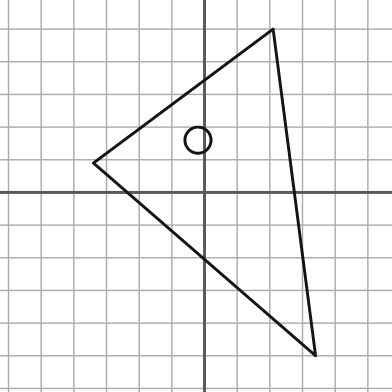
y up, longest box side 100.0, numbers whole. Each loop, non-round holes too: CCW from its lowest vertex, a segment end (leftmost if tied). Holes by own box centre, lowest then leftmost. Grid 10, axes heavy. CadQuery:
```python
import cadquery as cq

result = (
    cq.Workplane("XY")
    .moveTo(34.0, -50.0)
    .lineTo(21.0, 50.0)
    .lineTo(-34.0, 9.0)
    .close()
    .moveTo(-2.0, 16.0)
    .circle(4.0)
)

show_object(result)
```